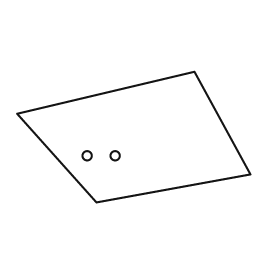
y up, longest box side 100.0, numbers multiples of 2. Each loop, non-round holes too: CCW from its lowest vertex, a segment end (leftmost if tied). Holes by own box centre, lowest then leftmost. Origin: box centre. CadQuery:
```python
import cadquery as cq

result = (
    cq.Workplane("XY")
    .moveTo(-16.0, -28.0)
    .lineTo(50.0, -16.0)
    .lineTo(26.0, 28.0)
    .lineTo(-50.0, 10.0)
    .close()
    .moveTo(-20.0, -8.0)
    .circle(2.0)
    .moveTo(-8.0, -8.0)
    .circle(2.0)
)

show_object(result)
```